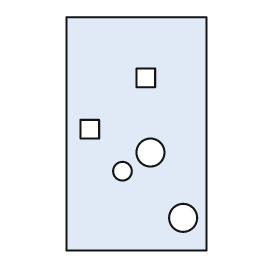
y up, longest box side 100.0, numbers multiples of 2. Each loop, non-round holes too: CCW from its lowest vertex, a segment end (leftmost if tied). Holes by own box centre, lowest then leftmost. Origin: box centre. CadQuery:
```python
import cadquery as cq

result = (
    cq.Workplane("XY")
    .moveTo(-30.0, -50.0)
    .lineTo(30.0, -50.0)
    .lineTo(30.0, 50.0)
    .lineTo(-30.0, 50.0)
    .close()
    .moveTo(20.0, -36.0)
    .circle(6.0)
    .moveTo(-6.0, -16.0)
    .circle(4.0)
    .moveTo(6.0, -8.0)
    .circle(6.0)
    .moveTo(-24.0, -2.0)
    .lineTo(-16.0, -2.0)
    .lineTo(-16.0, 6.0)
    .lineTo(-24.0, 6.0)
    .close()
    .moveTo(0.0, 20.0)
    .lineTo(8.0, 20.0)
    .lineTo(8.0, 28.0)
    .lineTo(0.0, 28.0)
    .close()
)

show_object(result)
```